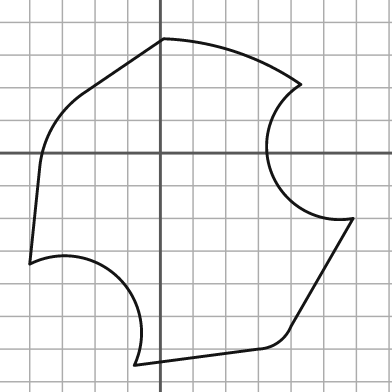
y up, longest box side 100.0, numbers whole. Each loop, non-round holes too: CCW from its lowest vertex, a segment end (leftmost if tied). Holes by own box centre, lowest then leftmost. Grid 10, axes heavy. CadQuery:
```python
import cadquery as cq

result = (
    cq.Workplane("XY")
    .moveTo(-8.0, -65.0)
    .lineTo(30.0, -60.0)
    .threePointArc((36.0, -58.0), (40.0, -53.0))
    .lineTo(59.0, -20.0)
    .threePointArc((34.0, -6.0), (43.0, 21.0))
    .threePointArc((23.0, 31.0), (1.0, 35.0))
    .lineTo(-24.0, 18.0)
    .threePointArc((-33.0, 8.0), (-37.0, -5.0))
    .lineTo(-40.0, -34.0)
    .threePointArc((-13.0, -38.0), (-8.0, -65.0))
    .close()
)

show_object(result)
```